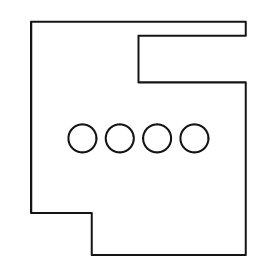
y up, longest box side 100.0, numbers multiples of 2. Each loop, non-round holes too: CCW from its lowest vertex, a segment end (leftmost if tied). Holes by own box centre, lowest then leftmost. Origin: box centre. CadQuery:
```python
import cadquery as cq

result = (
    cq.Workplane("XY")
    .moveTo(-20.0, -50.0)
    .lineTo(46.0, -50.0)
    .lineTo(46.0, 24.0)
    .lineTo(0.0, 24.0)
    .lineTo(0.0, 44.0)
    .lineTo(46.0, 44.0)
    .lineTo(46.0, 50.0)
    .lineTo(-46.0, 50.0)
    .lineTo(-46.0, -32.0)
    .lineTo(-20.0, -32.0)
    .close()
    .moveTo(-24.0, 0.0)
    .circle(6.0)
    .moveTo(-8.0, 0.0)
    .circle(6.0)
    .moveTo(8.0, 0.0)
    .circle(6.0)
    .moveTo(24.0, 0.0)
    .circle(6.0)
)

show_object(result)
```